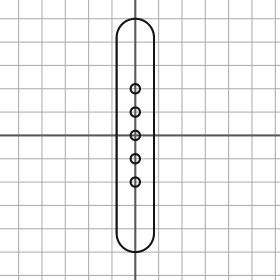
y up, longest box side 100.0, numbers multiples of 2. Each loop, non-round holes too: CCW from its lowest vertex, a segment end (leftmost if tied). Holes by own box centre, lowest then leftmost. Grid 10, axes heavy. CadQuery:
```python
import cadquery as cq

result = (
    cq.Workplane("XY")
    .moveTo(-8.0, -42.0)
    .threePointArc((0.0, -50.0), (8.0, -42.0))
    .lineTo(8.0, 42.0)
    .threePointArc((0.0, 50.0), (-8.0, 42.0))
    .close()
    .moveTo(0.0, -20.0)
    .circle(2.0)
    .moveTo(0.0, -10.0)
    .circle(2.0)
    .moveTo(0.0, 0.0)
    .circle(2.0)
    .moveTo(0.0, 10.0)
    .circle(2.0)
    .moveTo(0.0, 20.0)
    .circle(2.0)
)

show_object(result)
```